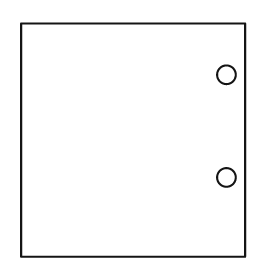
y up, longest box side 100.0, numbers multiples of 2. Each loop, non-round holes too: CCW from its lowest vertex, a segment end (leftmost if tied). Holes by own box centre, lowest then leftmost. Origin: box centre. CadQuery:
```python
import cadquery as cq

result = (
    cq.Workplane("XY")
    .moveTo(-48.0, -50.0)
    .lineTo(48.0, -50.0)
    .lineTo(48.0, 50.0)
    .lineTo(-48.0, 50.0)
    .close()
    .moveTo(40.0, -16.0)
    .circle(4.0)
    .moveTo(40.0, 28.0)
    .circle(4.0)
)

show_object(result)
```